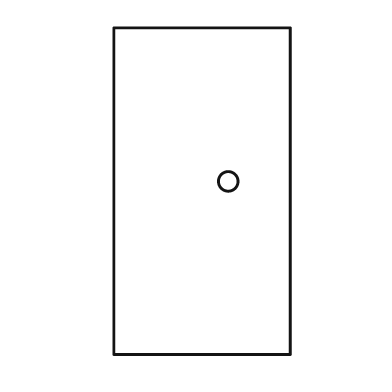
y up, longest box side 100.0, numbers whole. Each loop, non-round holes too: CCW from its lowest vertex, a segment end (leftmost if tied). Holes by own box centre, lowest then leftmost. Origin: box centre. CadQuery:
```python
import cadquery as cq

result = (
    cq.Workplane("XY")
    .moveTo(-27.0, -50.0)
    .lineTo(27.0, -50.0)
    .lineTo(27.0, 50.0)
    .lineTo(-27.0, 50.0)
    .close()
    .moveTo(8.0, 3.0)
    .circle(3.0)
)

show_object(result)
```